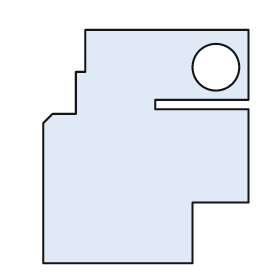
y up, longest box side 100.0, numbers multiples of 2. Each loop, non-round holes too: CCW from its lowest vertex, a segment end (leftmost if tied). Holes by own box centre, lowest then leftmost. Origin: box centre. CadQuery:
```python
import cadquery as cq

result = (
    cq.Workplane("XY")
    .moveTo(-44.0, -50.0)
    .lineTo(20.0, -50.0)
    .lineTo(20.0, -24.0)
    .lineTo(44.0, -24.0)
    .lineTo(44.0, 16.0)
    .lineTo(4.0, 16.0)
    .lineTo(4.0, 20.0)
    .lineTo(44.0, 20.0)
    .lineTo(44.0, 50.0)
    .lineTo(-26.0, 50.0)
    .lineTo(-26.0, 32.0)
    .lineTo(-30.0, 32.0)
    .lineTo(-30.0, 14.0)
    .lineTo(-40.0, 14.0)
    .lineTo(-44.0, 10.0)
    .close()
    .moveTo(30.0, 34.0)
    .circle(10.0)
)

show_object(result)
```